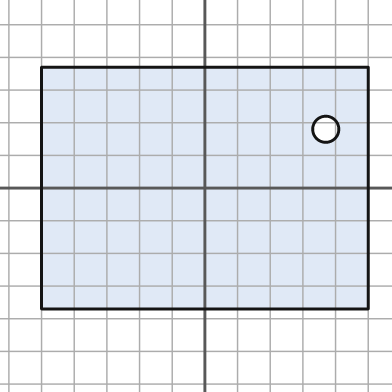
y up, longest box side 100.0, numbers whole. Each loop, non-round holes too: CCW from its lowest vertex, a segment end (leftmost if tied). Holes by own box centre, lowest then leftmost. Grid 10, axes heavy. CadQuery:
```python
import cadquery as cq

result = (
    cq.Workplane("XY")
    .moveTo(-50.0, -37.0)
    .lineTo(50.0, -37.0)
    .lineTo(50.0, 37.0)
    .lineTo(-50.0, 37.0)
    .close()
    .moveTo(37.0, 18.0)
    .circle(4.0)
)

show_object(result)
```